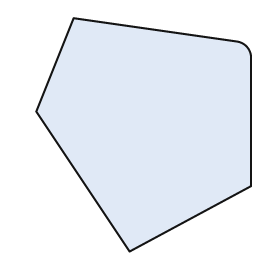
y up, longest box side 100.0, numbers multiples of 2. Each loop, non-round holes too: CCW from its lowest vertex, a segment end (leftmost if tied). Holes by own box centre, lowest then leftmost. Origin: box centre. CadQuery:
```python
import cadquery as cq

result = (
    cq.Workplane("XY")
    .moveTo(-6.0, -50.0)
    .lineTo(46.0, -22.0)
    .lineTo(46.0, 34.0)
    .threePointArc((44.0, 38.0), (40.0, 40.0))
    .lineTo(-30.0, 50.0)
    .lineTo(-46.0, 10.0)
    .close()
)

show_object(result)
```